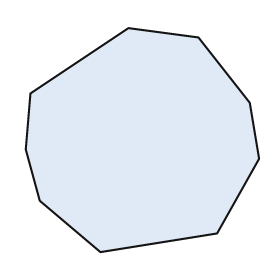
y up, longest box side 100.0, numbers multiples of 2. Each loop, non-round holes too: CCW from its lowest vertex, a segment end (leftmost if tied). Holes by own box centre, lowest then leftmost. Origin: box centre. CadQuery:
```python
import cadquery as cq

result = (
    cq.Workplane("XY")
    .moveTo(-18.0, -48.0)
    .lineTo(32.0, -40.0)
    .lineTo(50.0, -8.0)
    .lineTo(46.0, 16.0)
    .lineTo(24.0, 44.0)
    .lineTo(-6.0, 48.0)
    .lineTo(-48.0, 20.0)
    .lineTo(-50.0, -4.0)
    .lineTo(-44.0, -26.0)
    .close()
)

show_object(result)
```